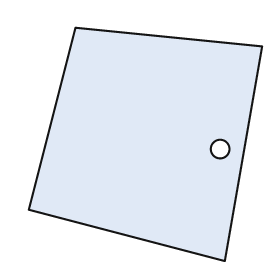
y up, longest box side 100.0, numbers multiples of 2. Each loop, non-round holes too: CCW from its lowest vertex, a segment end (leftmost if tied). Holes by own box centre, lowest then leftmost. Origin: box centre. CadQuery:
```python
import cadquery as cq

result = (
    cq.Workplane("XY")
    .moveTo(34.0, -50.0)
    .lineTo(50.0, 42.0)
    .lineTo(-30.0, 50.0)
    .lineTo(-50.0, -28.0)
    .close()
    .moveTo(32.0, -2.0)
    .circle(4.0)
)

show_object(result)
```